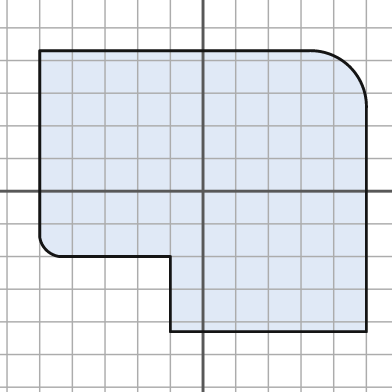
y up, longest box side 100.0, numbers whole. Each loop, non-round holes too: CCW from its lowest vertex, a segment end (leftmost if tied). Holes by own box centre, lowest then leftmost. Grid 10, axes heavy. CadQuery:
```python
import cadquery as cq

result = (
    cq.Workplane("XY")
    .moveTo(-10.0, -43.0)
    .lineTo(50.0, -43.0)
    .lineTo(50.0, 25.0)
    .threePointArc((45.0, 38.0), (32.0, 43.0))
    .lineTo(-50.0, 43.0)
    .lineTo(-50.0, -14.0)
    .threePointArc((-48.0, -18.0), (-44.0, -20.0))
    .lineTo(-10.0, -20.0)
    .close()
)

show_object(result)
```